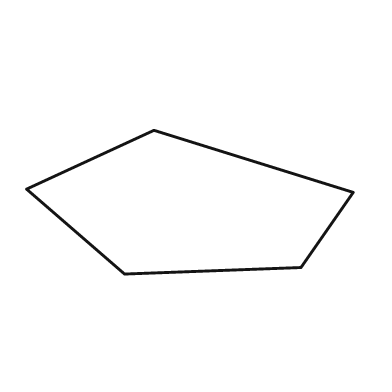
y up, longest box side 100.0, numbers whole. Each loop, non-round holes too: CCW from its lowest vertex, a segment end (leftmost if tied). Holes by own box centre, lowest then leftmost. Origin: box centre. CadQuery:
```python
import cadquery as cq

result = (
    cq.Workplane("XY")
    .moveTo(-20.0, -22.0)
    .lineTo(34.0, -20.0)
    .lineTo(50.0, 3.0)
    .lineTo(-11.0, 22.0)
    .lineTo(-50.0, 4.0)
    .close()
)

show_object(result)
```